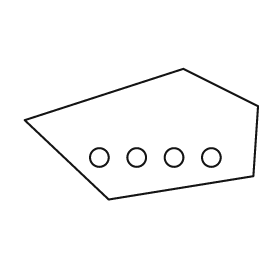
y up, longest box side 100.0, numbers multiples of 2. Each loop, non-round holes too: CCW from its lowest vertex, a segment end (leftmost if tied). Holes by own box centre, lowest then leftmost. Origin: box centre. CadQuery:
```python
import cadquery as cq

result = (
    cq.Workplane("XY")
    .moveTo(-14.0, -28.0)
    .lineTo(48.0, -18.0)
    .lineTo(50.0, 12.0)
    .lineTo(18.0, 28.0)
    .lineTo(-50.0, 6.0)
    .close()
    .moveTo(-18.0, -10.0)
    .circle(4.0)
    .moveTo(-2.0, -10.0)
    .circle(4.0)
    .moveTo(14.0, -10.0)
    .circle(4.0)
    .moveTo(30.0, -10.0)
    .circle(4.0)
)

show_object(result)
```